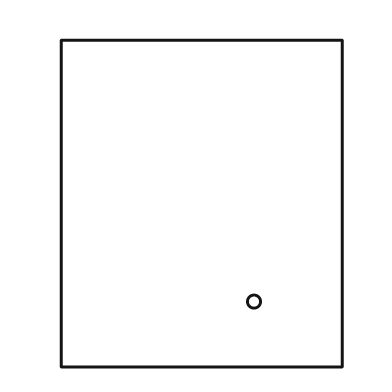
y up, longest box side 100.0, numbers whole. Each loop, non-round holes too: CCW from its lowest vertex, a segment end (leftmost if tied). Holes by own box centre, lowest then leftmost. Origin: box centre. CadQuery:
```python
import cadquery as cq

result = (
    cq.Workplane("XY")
    .moveTo(-43.0, -50.0)
    .lineTo(43.0, -50.0)
    .lineTo(43.0, 50.0)
    .lineTo(-43.0, 50.0)
    .close()
    .moveTo(16.0, -30.0)
    .circle(2.0)
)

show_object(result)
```